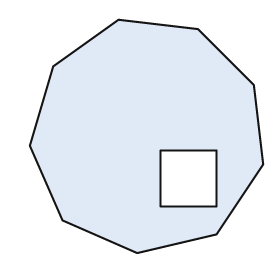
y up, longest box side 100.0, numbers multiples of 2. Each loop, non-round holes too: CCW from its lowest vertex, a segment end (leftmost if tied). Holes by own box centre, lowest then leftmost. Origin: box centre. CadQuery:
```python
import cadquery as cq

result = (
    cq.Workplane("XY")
    .moveTo(-4.0, -50.0)
    .lineTo(30.0, -42.0)
    .lineTo(50.0, -12.0)
    .lineTo(46.0, 22.0)
    .lineTo(22.0, 46.0)
    .lineTo(-12.0, 50.0)
    .lineTo(-40.0, 30.0)
    .lineTo(-50.0, -4.0)
    .lineTo(-36.0, -36.0)
    .close()
    .moveTo(6.0, -30.0)
    .lineTo(30.0, -30.0)
    .lineTo(30.0, -6.0)
    .lineTo(6.0, -6.0)
    .close()
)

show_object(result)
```